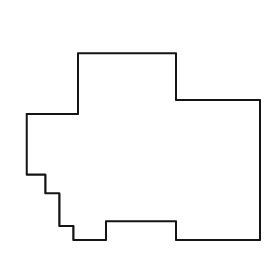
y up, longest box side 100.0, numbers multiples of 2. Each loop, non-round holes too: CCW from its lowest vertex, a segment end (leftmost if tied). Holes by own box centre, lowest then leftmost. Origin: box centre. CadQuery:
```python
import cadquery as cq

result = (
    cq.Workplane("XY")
    .moveTo(-30.0, -40.0)
    .lineTo(-16.0, -40.0)
    .lineTo(-16.0, -32.0)
    .lineTo(14.0, -32.0)
    .lineTo(14.0, -40.0)
    .lineTo(50.0, -40.0)
    .lineTo(50.0, 20.0)
    .lineTo(14.0, 20.0)
    .lineTo(14.0, 40.0)
    .lineTo(-28.0, 40.0)
    .lineTo(-28.0, 14.0)
    .lineTo(-50.0, 14.0)
    .lineTo(-50.0, -12.0)
    .lineTo(-42.0, -12.0)
    .lineTo(-42.0, -20.0)
    .lineTo(-36.0, -20.0)
    .lineTo(-36.0, -34.0)
    .lineTo(-30.0, -34.0)
    .close()
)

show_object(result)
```